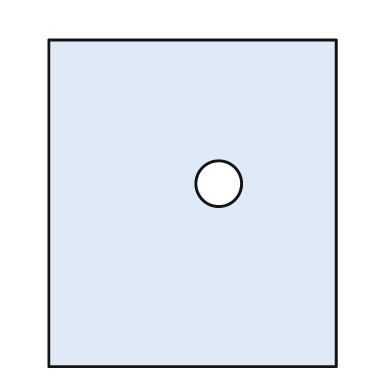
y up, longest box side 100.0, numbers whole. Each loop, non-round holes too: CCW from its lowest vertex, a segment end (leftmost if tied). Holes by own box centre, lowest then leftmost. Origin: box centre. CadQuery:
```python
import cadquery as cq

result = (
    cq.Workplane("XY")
    .moveTo(-44.0, -50.0)
    .lineTo(44.0, -50.0)
    .lineTo(44.0, 50.0)
    .lineTo(-44.0, 50.0)
    .close()
    .moveTo(8.0, 6.0)
    .circle(7.0)
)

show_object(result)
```